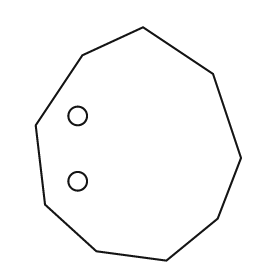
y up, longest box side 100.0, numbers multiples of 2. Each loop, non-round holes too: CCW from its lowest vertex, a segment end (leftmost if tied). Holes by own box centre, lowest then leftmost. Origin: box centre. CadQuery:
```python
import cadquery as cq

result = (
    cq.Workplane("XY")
    .moveTo(12.0, -50.0)
    .lineTo(34.0, -32.0)
    .lineTo(44.0, -6.0)
    .lineTo(32.0, 30.0)
    .lineTo(2.0, 50.0)
    .lineTo(-24.0, 38.0)
    .lineTo(-44.0, 8.0)
    .lineTo(-40.0, -26.0)
    .lineTo(-18.0, -46.0)
    .close()
    .moveTo(-26.0, -16.0)
    .circle(4.0)
    .moveTo(-26.0, 12.0)
    .circle(4.0)
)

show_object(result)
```